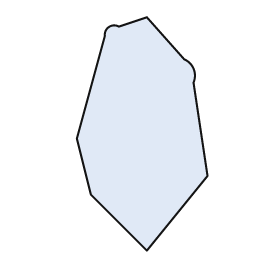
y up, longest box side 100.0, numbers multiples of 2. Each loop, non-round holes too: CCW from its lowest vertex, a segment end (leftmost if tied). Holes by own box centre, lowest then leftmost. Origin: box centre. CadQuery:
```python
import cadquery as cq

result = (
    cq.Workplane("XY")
    .moveTo(2.0, -50.0)
    .lineTo(28.0, -18.0)
    .lineTo(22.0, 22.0)
    .threePointArc((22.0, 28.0), (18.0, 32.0))
    .lineTo(2.0, 50.0)
    .lineTo(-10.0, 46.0)
    .threePointArc((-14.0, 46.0), (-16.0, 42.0))
    .lineTo(-28.0, -2.0)
    .lineTo(-22.0, -26.0)
    .close()
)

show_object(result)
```